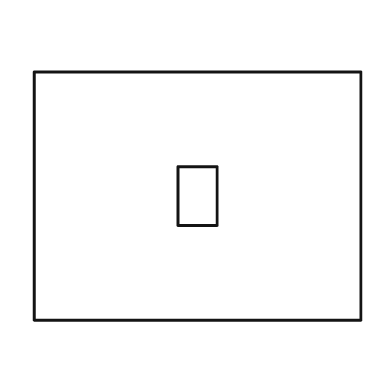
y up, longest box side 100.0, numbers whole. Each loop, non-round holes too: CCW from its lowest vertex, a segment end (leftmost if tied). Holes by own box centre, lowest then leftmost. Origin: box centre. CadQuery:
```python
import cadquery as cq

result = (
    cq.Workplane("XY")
    .moveTo(-50.0, -38.0)
    .lineTo(50.0, -38.0)
    .lineTo(50.0, 38.0)
    .lineTo(-50.0, 38.0)
    .close()
    .moveTo(-6.0, -9.0)
    .lineTo(6.0, -9.0)
    .lineTo(6.0, 9.0)
    .lineTo(-6.0, 9.0)
    .close()
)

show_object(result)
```